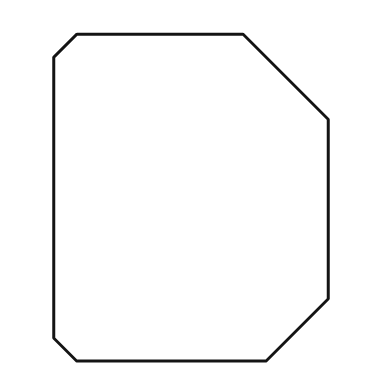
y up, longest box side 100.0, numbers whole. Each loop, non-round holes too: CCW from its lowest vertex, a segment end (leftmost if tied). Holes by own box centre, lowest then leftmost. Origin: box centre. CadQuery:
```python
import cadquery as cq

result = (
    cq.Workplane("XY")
    .moveTo(-35.0, -50.0)
    .lineTo(23.0, -50.0)
    .lineTo(42.0, -31.0)
    .lineTo(42.0, 24.0)
    .lineTo(16.0, 50.0)
    .lineTo(-35.0, 50.0)
    .lineTo(-42.0, 43.0)
    .lineTo(-42.0, -43.0)
    .close()
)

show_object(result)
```